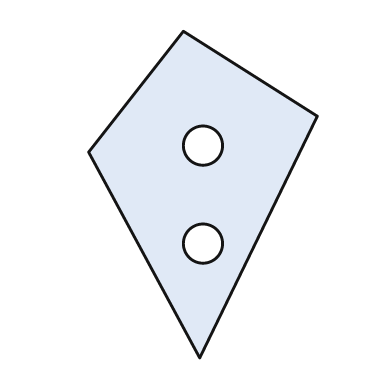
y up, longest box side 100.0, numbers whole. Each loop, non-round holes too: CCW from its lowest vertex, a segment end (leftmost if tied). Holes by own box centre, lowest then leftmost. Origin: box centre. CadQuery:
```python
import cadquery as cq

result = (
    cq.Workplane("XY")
    .moveTo(-1.0, -50.0)
    .lineTo(35.0, 24.0)
    .lineTo(-6.0, 50.0)
    .lineTo(-35.0, 13.0)
    .close()
    .moveTo(0.0, -15.0)
    .circle(6.0)
    .moveTo(0.0, 15.0)
    .circle(6.0)
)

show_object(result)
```